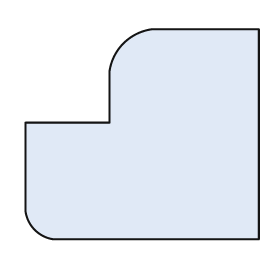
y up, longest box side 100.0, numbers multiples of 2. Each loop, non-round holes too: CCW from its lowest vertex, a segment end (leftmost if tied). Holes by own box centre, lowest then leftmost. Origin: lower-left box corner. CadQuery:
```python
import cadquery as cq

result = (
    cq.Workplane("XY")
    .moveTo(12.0, 0.0)
    .lineTo(100.0, 0.0)
    .lineTo(100.0, 90.0)
    .lineTo(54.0, 90.0)
    .threePointArc((42.0, 84.0), (36.0, 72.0))
    .lineTo(36.0, 50.0)
    .lineTo(0.0, 50.0)
    .lineTo(0.0, 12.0)
    .threePointArc((4.0, 4.0), (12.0, 0.0))
    .close()
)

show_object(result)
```